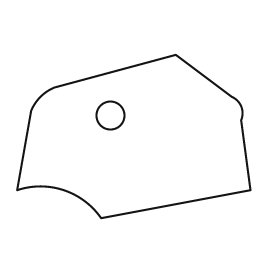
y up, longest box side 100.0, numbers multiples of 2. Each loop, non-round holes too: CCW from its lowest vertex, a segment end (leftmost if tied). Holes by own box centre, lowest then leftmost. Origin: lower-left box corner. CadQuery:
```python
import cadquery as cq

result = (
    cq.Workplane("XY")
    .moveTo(36.0, 0.0)
    .lineTo(100.0, 12.0)
    .lineTo(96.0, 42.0)
    .threePointArc((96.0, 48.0), (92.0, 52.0))
    .lineTo(68.0, 70.0)
    .lineTo(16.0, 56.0)
    .threePointArc((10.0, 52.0), (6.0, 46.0))
    .lineTo(0.0, 12.0)
    .threePointArc((20.0, 12.0), (36.0, 0.0))
    .close()
    .moveTo(40.0, 44.0)
    .circle(6.0)
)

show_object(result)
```